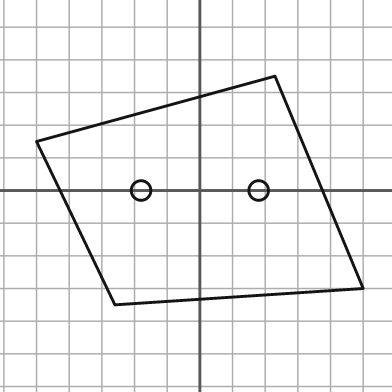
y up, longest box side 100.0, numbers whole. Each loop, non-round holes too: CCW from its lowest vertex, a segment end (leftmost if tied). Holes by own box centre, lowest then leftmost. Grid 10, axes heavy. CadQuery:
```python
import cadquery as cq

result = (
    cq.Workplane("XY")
    .moveTo(-26.0, -35.0)
    .lineTo(50.0, -30.0)
    .lineTo(23.0, 35.0)
    .lineTo(-50.0, 15.0)
    .close()
    .moveTo(-18.0, 0.0)
    .circle(3.0)
    .moveTo(18.0, 0.0)
    .circle(3.0)
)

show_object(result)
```